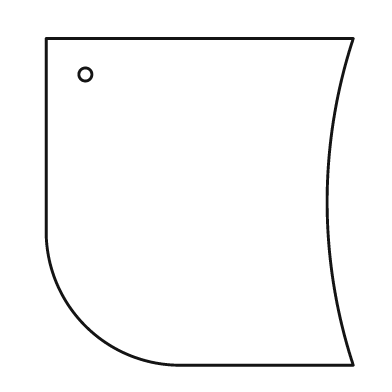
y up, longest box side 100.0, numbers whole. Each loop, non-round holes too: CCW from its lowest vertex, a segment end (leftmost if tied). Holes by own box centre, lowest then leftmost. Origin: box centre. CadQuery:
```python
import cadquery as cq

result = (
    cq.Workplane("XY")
    .moveTo(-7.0, -50.0)
    .lineTo(47.0, -50.0)
    .threePointArc((39.0, 0.0), (47.0, 50.0))
    .lineTo(-47.0, 50.0)
    .lineTo(-47.0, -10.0)
    .threePointArc((-35.0, -38.0), (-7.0, -50.0))
    .close()
    .moveTo(-35.0, 39.0)
    .circle(2.0)
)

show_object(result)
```